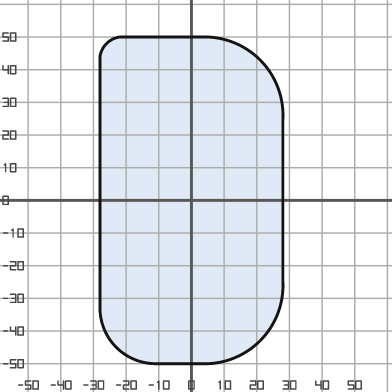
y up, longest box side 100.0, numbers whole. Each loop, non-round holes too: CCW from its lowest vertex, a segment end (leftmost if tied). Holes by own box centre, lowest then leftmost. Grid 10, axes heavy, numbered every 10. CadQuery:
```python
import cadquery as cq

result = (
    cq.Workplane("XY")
    .moveTo(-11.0, -50.0)
    .lineTo(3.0, -50.0)
    .threePointArc((21.0, -43.0), (28.0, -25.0))
    .lineTo(28.0, 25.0)
    .threePointArc((21.0, 43.0), (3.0, 50.0))
    .lineTo(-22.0, 50.0)
    .threePointArc((-26.0, 48.0), (-28.0, 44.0))
    .lineTo(-28.0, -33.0)
    .threePointArc((-23.0, -45.0), (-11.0, -50.0))
    .close()
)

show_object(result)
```